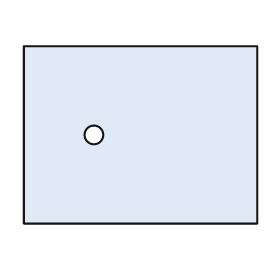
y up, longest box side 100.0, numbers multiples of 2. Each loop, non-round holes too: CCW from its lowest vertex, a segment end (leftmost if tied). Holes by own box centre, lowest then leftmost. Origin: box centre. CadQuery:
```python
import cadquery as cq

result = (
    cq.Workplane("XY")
    .moveTo(-50.0, -38.0)
    .lineTo(50.0, -38.0)
    .lineTo(50.0, 38.0)
    .lineTo(-50.0, 38.0)
    .close()
    .moveTo(-20.0, 0.0)
    .circle(4.0)
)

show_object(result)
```